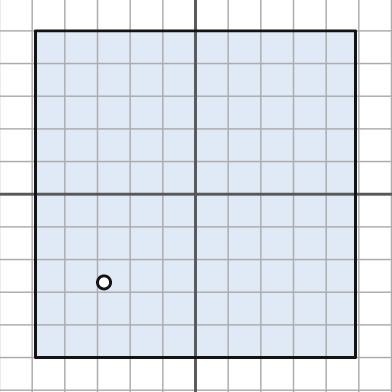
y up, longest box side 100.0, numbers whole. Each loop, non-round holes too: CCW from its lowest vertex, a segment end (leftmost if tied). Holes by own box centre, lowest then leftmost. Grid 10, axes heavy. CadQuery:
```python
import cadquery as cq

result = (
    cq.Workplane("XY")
    .moveTo(-49.0, -50.0)
    .lineTo(49.0, -50.0)
    .lineTo(49.0, 50.0)
    .lineTo(-49.0, 50.0)
    .close()
    .moveTo(-28.0, -27.0)
    .circle(2.0)
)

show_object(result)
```